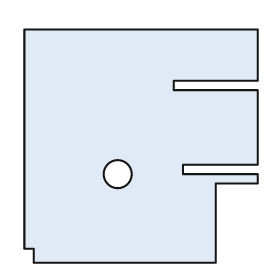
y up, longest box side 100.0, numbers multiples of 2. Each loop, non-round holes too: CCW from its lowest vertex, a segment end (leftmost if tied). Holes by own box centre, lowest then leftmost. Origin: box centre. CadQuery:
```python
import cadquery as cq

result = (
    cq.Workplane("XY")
    .moveTo(-46.0, -50.0)
    .lineTo(32.0, -50.0)
    .lineTo(32.0, -16.0)
    .lineTo(50.0, -16.0)
    .lineTo(50.0, -12.0)
    .lineTo(18.0, -12.0)
    .lineTo(18.0, -8.0)
    .lineTo(50.0, -8.0)
    .lineTo(50.0, 24.0)
    .lineTo(14.0, 24.0)
    .lineTo(14.0, 28.0)
    .lineTo(50.0, 28.0)
    .lineTo(50.0, 50.0)
    .lineTo(-50.0, 50.0)
    .lineTo(-50.0, -44.0)
    .lineTo(-46.0, -44.0)
    .close()
    .moveTo(-10.0, -12.0)
    .circle(6.0)
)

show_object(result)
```